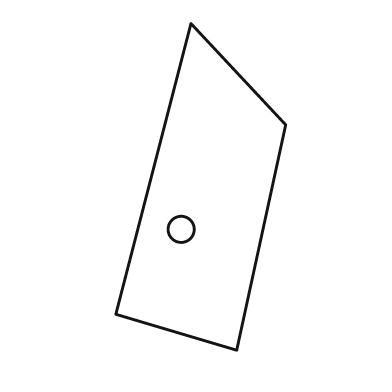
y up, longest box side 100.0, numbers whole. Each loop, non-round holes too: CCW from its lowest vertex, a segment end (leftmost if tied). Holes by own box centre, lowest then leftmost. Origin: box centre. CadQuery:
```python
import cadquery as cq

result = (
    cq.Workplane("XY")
    .moveTo(11.0, -50.0)
    .lineTo(26.0, 19.0)
    .lineTo(-3.0, 50.0)
    .lineTo(-26.0, -39.0)
    .close()
    .moveTo(-6.0, -13.0)
    .circle(4.0)
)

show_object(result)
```